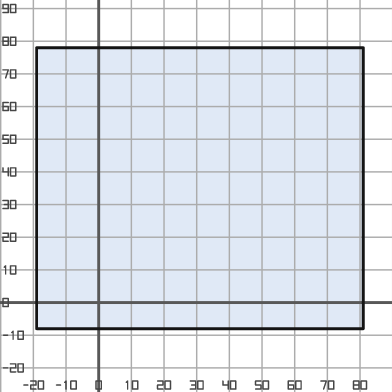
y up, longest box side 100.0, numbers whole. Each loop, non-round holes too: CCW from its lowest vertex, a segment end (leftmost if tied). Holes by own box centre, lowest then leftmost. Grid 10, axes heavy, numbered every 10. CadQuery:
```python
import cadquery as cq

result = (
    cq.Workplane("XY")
    .moveTo(-19.0, -8.0)
    .lineTo(81.0, -8.0)
    .lineTo(81.0, 78.0)
    .lineTo(-19.0, 78.0)
    .close()
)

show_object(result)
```